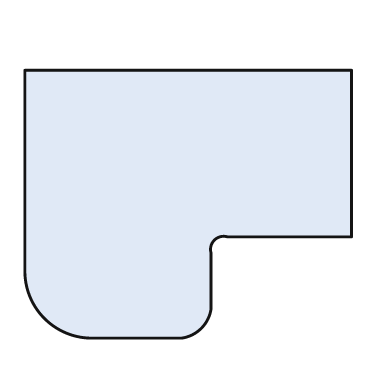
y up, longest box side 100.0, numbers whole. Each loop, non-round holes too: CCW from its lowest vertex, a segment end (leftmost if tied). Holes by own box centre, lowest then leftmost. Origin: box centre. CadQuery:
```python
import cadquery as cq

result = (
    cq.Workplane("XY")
    .moveTo(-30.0, -41.0)
    .lineTo(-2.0, -41.0)
    .threePointArc((4.0, -38.0), (7.0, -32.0))
    .lineTo(7.0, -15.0)
    .threePointArc((8.0, -11.0), (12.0, -10.0))
    .lineTo(50.0, -10.0)
    .lineTo(50.0, 41.0)
    .lineTo(-50.0, 41.0)
    .lineTo(-50.0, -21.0)
    .threePointArc((-44.0, -35.0), (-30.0, -41.0))
    .close()
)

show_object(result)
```